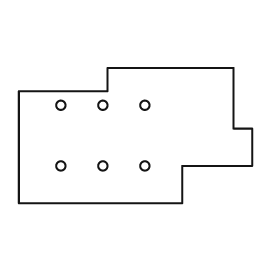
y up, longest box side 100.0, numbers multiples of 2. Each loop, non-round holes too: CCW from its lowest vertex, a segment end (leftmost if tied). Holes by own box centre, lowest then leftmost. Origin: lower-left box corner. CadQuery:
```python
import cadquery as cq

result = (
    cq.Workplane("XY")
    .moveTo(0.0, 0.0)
    .lineTo(70.0, 0.0)
    .lineTo(70.0, 16.0)
    .lineTo(100.0, 16.0)
    .lineTo(100.0, 32.0)
    .lineTo(92.0, 32.0)
    .lineTo(92.0, 58.0)
    .lineTo(38.0, 58.0)
    .lineTo(38.0, 48.0)
    .lineTo(0.0, 48.0)
    .close()
    .moveTo(18.0, 16.0)
    .circle(2.0)
    .moveTo(36.0, 16.0)
    .circle(2.0)
    .moveTo(54.0, 16.0)
    .circle(2.0)
    .moveTo(18.0, 42.0)
    .circle(2.0)
    .moveTo(36.0, 42.0)
    .circle(2.0)
    .moveTo(54.0, 42.0)
    .circle(2.0)
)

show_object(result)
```